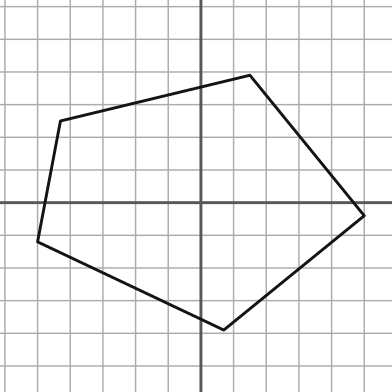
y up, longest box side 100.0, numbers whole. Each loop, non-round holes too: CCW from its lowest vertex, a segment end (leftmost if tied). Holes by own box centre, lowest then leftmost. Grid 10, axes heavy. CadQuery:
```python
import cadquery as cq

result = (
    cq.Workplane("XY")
    .moveTo(7.0, -39.0)
    .lineTo(50.0, -4.0)
    .lineTo(15.0, 39.0)
    .lineTo(-43.0, 25.0)
    .lineTo(-50.0, -12.0)
    .close()
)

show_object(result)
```